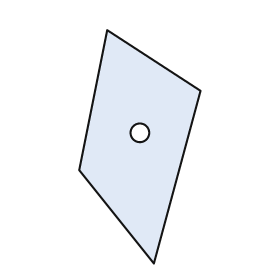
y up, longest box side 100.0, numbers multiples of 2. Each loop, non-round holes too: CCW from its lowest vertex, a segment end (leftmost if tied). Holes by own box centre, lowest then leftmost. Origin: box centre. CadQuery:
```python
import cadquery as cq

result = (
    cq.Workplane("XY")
    .moveTo(6.0, -50.0)
    .lineTo(26.0, 24.0)
    .lineTo(-14.0, 50.0)
    .lineTo(-26.0, -10.0)
    .close()
    .moveTo(0.0, 6.0)
    .circle(4.0)
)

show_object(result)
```